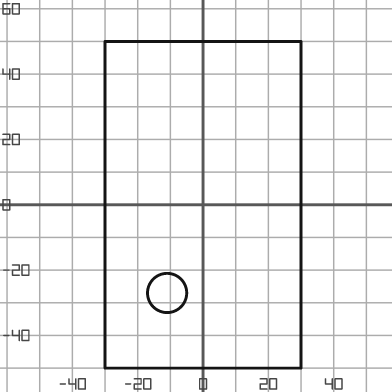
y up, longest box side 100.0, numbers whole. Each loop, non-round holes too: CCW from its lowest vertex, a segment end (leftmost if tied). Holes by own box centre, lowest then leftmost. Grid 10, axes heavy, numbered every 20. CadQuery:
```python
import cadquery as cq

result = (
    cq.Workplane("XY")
    .moveTo(-30.0, -50.0)
    .lineTo(30.0, -50.0)
    .lineTo(30.0, 50.0)
    .lineTo(-30.0, 50.0)
    .close()
    .moveTo(-11.0, -27.0)
    .circle(6.0)
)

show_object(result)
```